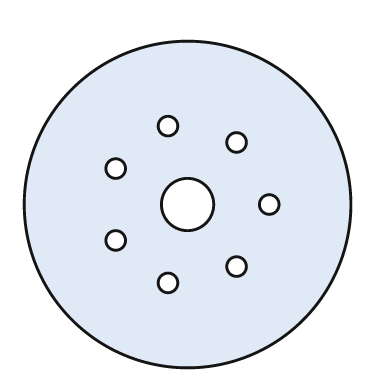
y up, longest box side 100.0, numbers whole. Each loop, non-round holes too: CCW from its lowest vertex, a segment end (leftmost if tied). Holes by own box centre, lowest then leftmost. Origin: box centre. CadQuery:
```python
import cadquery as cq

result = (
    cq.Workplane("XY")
    .moveTo(0.0, 0.0)
    .circle(50.0)
    .moveTo(-6.0, -24.0)
    .circle(3.0)
    .moveTo(15.0, -19.0)
    .circle(3.0)
    .moveTo(-22.0, -11.0)
    .circle(3.0)
    .moveTo(0.0, 0.0)
    .circle(8.0)
    .moveTo(25.0, 0.0)
    .circle(3.0)
    .moveTo(-22.0, 11.0)
    .circle(3.0)
    .moveTo(15.0, 19.0)
    .circle(3.0)
    .moveTo(-6.0, 24.0)
    .circle(3.0)
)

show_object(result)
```